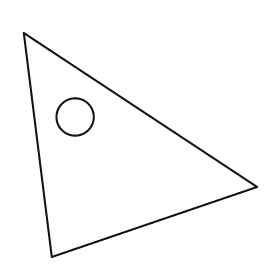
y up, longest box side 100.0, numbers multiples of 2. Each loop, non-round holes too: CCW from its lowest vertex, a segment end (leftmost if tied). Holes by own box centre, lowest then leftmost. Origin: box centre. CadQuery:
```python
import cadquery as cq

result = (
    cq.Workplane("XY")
    .moveTo(-38.0, -48.0)
    .lineTo(50.0, -18.0)
    .lineTo(-50.0, 48.0)
    .close()
    .moveTo(-28.0, 12.0)
    .circle(8.0)
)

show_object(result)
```